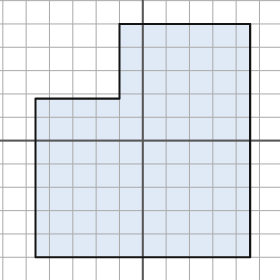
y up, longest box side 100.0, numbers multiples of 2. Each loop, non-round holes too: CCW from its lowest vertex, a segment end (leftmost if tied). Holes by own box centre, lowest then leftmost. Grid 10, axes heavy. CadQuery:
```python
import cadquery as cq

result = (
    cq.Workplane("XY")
    .moveTo(-46.0, -50.0)
    .lineTo(46.0, -50.0)
    .lineTo(46.0, 50.0)
    .lineTo(-10.0, 50.0)
    .lineTo(-10.0, 18.0)
    .lineTo(-46.0, 18.0)
    .close()
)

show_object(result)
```